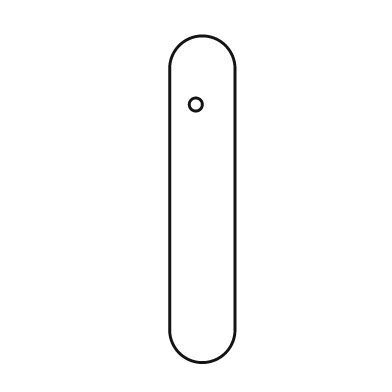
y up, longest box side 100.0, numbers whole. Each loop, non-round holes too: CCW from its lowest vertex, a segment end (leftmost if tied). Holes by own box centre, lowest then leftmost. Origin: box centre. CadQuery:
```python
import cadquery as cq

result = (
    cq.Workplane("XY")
    .moveTo(-10.0, -40.0)
    .threePointArc((0.0, -50.0), (10.0, -40.0))
    .lineTo(10.0, 40.0)
    .threePointArc((0.0, 50.0), (-10.0, 40.0))
    .close()
    .moveTo(-2.0, 29.0)
    .circle(2.0)
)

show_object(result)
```